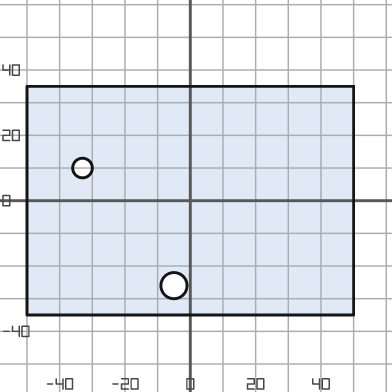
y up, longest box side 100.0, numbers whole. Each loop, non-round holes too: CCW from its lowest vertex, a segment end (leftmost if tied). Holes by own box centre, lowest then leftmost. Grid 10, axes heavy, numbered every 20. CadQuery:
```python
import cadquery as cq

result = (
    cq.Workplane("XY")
    .moveTo(-50.0, -35.0)
    .lineTo(50.0, -35.0)
    .lineTo(50.0, 35.0)
    .lineTo(-50.0, 35.0)
    .close()
    .moveTo(-5.0, -26.0)
    .circle(4.0)
    .moveTo(-33.0, 10.0)
    .circle(3.0)
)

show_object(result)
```